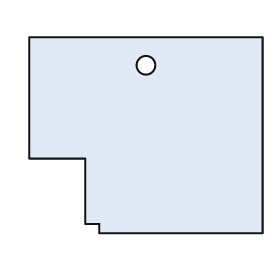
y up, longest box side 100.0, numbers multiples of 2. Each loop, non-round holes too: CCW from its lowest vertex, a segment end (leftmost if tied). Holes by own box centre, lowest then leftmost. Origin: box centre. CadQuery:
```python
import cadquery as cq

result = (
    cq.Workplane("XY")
    .moveTo(-20.0, -42.0)
    .lineTo(50.0, -42.0)
    .lineTo(50.0, 42.0)
    .lineTo(-50.0, 42.0)
    .lineTo(-50.0, -10.0)
    .lineTo(-26.0, -10.0)
    .lineTo(-26.0, -38.0)
    .lineTo(-20.0, -38.0)
    .close()
    .moveTo(0.0, 30.0)
    .circle(4.0)
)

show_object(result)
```